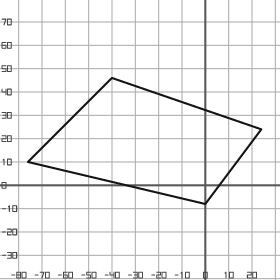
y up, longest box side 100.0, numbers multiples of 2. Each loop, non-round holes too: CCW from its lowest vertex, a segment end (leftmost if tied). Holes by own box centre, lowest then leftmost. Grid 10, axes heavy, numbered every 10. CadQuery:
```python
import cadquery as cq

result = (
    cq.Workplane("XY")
    .moveTo(0.0, -8.0)
    .lineTo(24.0, 24.0)
    .lineTo(-40.0, 46.0)
    .lineTo(-76.0, 10.0)
    .close()
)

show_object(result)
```